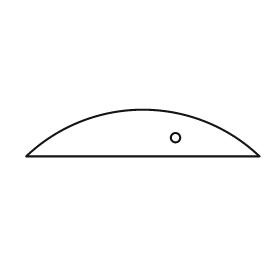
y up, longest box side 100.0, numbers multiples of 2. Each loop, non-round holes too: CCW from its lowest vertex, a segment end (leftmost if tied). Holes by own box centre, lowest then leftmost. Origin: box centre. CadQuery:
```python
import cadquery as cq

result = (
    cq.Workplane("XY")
    .moveTo(-50.0, -10.0)
    .lineTo(50.0, -10.0)
    .threePointArc((0.0, 10.0), (-50.0, -10.0))
    .close()
    .moveTo(14.0, -2.0)
    .circle(2.0)
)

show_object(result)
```